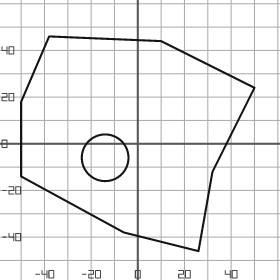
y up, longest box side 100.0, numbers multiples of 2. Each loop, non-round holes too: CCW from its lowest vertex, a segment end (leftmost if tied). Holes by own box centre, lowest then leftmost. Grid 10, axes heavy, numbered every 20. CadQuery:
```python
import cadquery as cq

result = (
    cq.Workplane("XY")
    .moveTo(26.0, -46.0)
    .lineTo(32.0, -12.0)
    .lineTo(50.0, 24.0)
    .lineTo(10.0, 44.0)
    .lineTo(-38.0, 46.0)
    .lineTo(-50.0, 18.0)
    .lineTo(-50.0, -14.0)
    .lineTo(-6.0, -38.0)
    .close()
    .moveTo(-14.0, -6.0)
    .circle(10.0)
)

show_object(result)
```